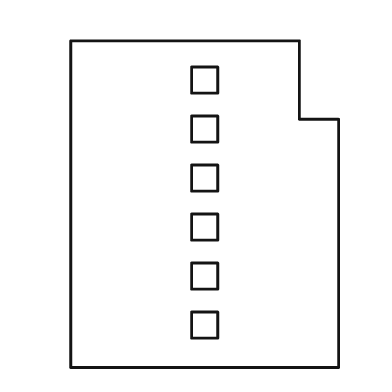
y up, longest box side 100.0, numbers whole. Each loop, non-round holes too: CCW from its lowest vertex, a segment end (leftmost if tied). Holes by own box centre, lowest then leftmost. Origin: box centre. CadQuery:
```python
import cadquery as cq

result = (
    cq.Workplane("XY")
    .moveTo(-41.0, -50.0)
    .lineTo(41.0, -50.0)
    .lineTo(41.0, 26.0)
    .lineTo(29.0, 26.0)
    .lineTo(29.0, 50.0)
    .lineTo(-41.0, 50.0)
    .close()
    .moveTo(-4.0, -41.0)
    .lineTo(4.0, -41.0)
    .lineTo(4.0, -33.0)
    .lineTo(-4.0, -33.0)
    .close()
    .moveTo(-4.0, -26.0)
    .lineTo(4.0, -26.0)
    .lineTo(4.0, -18.0)
    .lineTo(-4.0, -18.0)
    .close()
    .moveTo(-4.0, -11.0)
    .lineTo(4.0, -11.0)
    .lineTo(4.0, -3.0)
    .lineTo(-4.0, -3.0)
    .close()
    .moveTo(-4.0, 4.0)
    .lineTo(4.0, 4.0)
    .lineTo(4.0, 12.0)
    .lineTo(-4.0, 12.0)
    .close()
    .moveTo(-4.0, 19.0)
    .lineTo(4.0, 19.0)
    .lineTo(4.0, 27.0)
    .lineTo(-4.0, 27.0)
    .close()
    .moveTo(-4.0, 34.0)
    .lineTo(4.0, 34.0)
    .lineTo(4.0, 42.0)
    .lineTo(-4.0, 42.0)
    .close()
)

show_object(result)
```